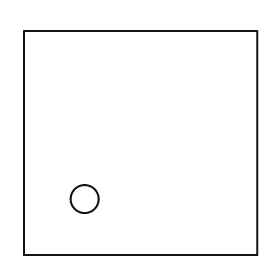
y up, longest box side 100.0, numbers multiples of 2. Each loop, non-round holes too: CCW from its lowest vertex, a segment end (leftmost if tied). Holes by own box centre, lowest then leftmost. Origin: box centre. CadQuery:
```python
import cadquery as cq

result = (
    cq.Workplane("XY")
    .moveTo(-50.0, -48.0)
    .lineTo(50.0, -48.0)
    .lineTo(50.0, 48.0)
    .lineTo(-50.0, 48.0)
    .close()
    .moveTo(-24.0, -24.0)
    .circle(6.0)
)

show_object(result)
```